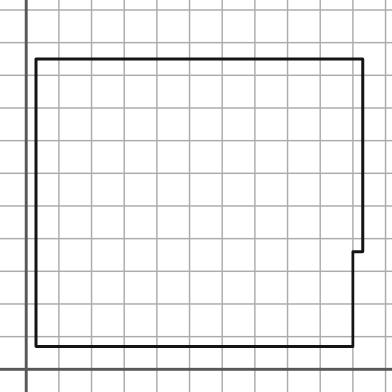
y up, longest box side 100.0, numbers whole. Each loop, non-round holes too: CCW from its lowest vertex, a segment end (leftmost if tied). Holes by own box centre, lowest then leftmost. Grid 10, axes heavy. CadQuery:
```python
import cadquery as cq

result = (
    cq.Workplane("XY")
    .moveTo(3.0, 7.0)
    .lineTo(100.0, 7.0)
    .lineTo(100.0, 36.0)
    .lineTo(103.0, 36.0)
    .lineTo(103.0, 95.0)
    .lineTo(3.0, 95.0)
    .close()
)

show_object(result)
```